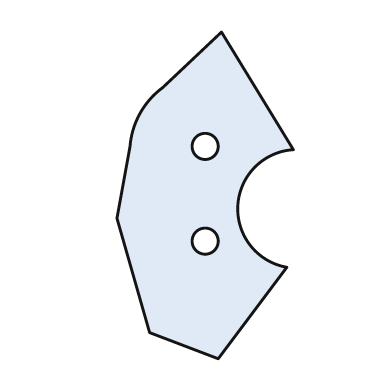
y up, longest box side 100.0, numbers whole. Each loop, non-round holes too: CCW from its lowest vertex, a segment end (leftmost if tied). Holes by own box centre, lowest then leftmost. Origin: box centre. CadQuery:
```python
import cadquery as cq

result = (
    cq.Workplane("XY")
    .moveTo(4.0, -50.0)
    .lineTo(25.0, -22.0)
    .threePointArc((10.0, -3.0), (27.0, 14.0))
    .lineTo(5.0, 50.0)
    .lineTo(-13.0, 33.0)
    .threePointArc((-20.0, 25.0), (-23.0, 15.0))
    .lineTo(-27.0, -7.0)
    .lineTo(-17.0, -42.0)
    .close()
    .moveTo(0.0, -14.0)
    .circle(4.0)
    .moveTo(0.0, 15.0)
    .circle(4.0)
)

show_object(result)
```